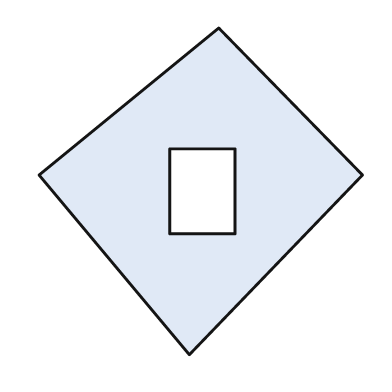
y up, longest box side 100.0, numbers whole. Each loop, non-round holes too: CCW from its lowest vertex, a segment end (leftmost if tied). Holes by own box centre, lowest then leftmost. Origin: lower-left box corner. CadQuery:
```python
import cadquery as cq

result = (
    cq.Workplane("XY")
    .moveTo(46.0, 0.0)
    .lineTo(99.0, 55.0)
    .lineTo(55.0, 100.0)
    .lineTo(0.0, 55.0)
    .close()
    .moveTo(40.0, 37.0)
    .lineTo(60.0, 37.0)
    .lineTo(60.0, 63.0)
    .lineTo(40.0, 63.0)
    .close()
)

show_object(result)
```